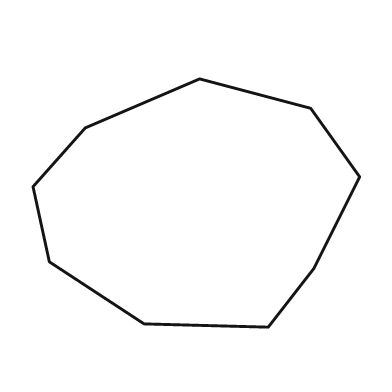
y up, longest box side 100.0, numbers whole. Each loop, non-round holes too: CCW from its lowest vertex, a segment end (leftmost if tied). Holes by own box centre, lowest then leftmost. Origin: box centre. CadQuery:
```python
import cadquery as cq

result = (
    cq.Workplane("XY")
    .moveTo(22.0, -38.0)
    .lineTo(36.0, -20.0)
    .lineTo(50.0, 8.0)
    .lineTo(35.0, 29.0)
    .lineTo(1.0, 38.0)
    .lineTo(-34.0, 23.0)
    .lineTo(-50.0, 5.0)
    .lineTo(-45.0, -18.0)
    .lineTo(-16.0, -37.0)
    .close()
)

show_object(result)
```